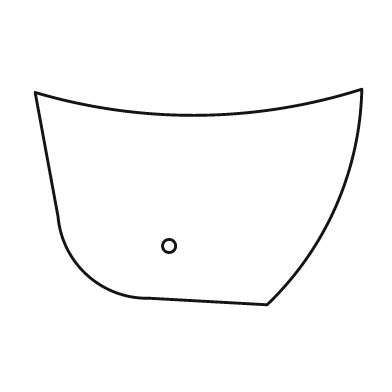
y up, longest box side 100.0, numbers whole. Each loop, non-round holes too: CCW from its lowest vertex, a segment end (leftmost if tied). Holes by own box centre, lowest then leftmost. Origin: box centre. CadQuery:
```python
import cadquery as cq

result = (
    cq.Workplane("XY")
    .moveTo(21.0, -33.0)
    .threePointArc((42.0, -3.0), (50.0, 33.0))
    .threePointArc((0.0, 25.0), (-50.0, 32.0))
    .lineTo(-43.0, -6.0)
    .threePointArc((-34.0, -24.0), (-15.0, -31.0))
    .close()
    .moveTo(-9.0, -15.0)
    .circle(2.0)
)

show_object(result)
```